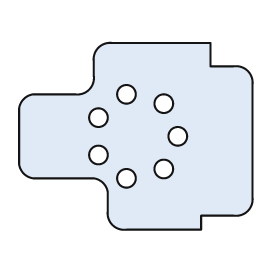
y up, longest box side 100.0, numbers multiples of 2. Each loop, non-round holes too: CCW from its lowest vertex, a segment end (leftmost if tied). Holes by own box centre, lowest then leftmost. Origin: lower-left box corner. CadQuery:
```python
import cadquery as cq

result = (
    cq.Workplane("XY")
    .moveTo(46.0, 0.0)
    .lineTo(78.0, 0.0)
    .lineTo(78.0, 6.0)
    .lineTo(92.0, 6.0)
    .threePointArc((98.0, 8.0), (100.0, 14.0))
    .lineTo(100.0, 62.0)
    .threePointArc((98.0, 68.0), (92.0, 70.0))
    .lineTo(82.0, 70.0)
    .lineTo(82.0, 80.0)
    .lineTo(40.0, 80.0)
    .threePointArc((34.0, 78.0), (32.0, 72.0))
    .lineTo(32.0, 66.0)
    .threePointArc((30.0, 60.0), (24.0, 58.0))
    .lineTo(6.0, 58.0)
    .threePointArc((2.0, 56.0), (0.0, 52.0))
    .lineTo(0.0, 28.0)
    .threePointArc((2.0, 24.0), (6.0, 22.0))
    .lineTo(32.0, 22.0)
    .threePointArc((36.0, 20.0), (38.0, 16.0))
    .lineTo(38.0, 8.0)
    .threePointArc((40.0, 2.0), (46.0, 0.0))
    .close()
    .moveTo(46.0, 22.0)
    .circle(4.0)
    .moveTo(62.0, 26.0)
    .circle(4.0)
    .moveTo(34.0, 32.0)
    .circle(4.0)
    .moveTo(68.0, 40.0)
    .circle(4.0)
    .moveTo(34.0, 48.0)
    .circle(4.0)
    .moveTo(62.0, 54.0)
    .circle(4.0)
    .moveTo(46.0, 58.0)
    .circle(4.0)
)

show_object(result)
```